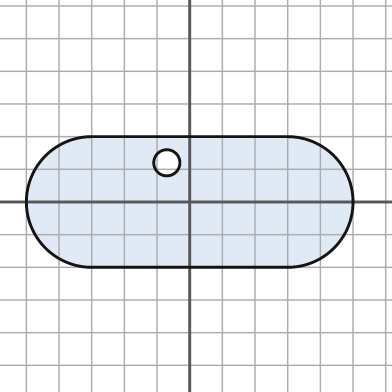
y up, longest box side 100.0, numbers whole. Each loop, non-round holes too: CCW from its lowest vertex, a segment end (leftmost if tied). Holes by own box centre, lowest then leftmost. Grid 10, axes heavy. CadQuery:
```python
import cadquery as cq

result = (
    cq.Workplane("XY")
    .moveTo(-30.0, -20.0)
    .lineTo(30.0, -20.0)
    .threePointArc((50.0, 0.0), (30.0, 20.0))
    .lineTo(-30.0, 20.0)
    .threePointArc((-50.0, 0.0), (-30.0, -20.0))
    .close()
    .moveTo(-7.0, 12.0)
    .circle(4.0)
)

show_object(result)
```